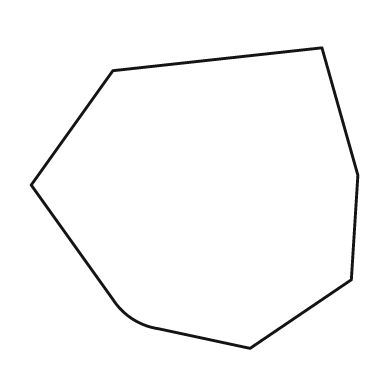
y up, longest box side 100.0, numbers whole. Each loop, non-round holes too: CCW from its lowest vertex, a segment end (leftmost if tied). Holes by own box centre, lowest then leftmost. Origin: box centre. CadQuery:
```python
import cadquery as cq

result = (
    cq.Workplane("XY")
    .moveTo(17.0, -46.0)
    .lineTo(48.0, -25.0)
    .lineTo(50.0, 7.0)
    .lineTo(39.0, 46.0)
    .lineTo(-25.0, 39.0)
    .lineTo(-50.0, 4.0)
    .lineTo(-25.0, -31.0)
    .threePointArc((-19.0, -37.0), (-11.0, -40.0))
    .close()
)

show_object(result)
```